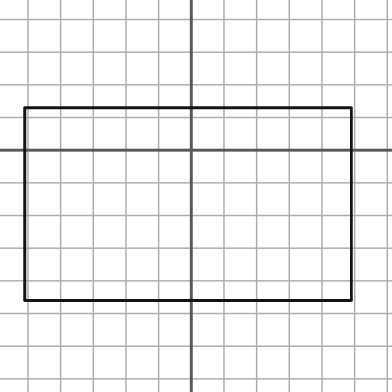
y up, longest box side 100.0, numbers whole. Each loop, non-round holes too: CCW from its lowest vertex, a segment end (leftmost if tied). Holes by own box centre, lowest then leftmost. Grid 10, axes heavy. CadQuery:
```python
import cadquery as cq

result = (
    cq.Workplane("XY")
    .moveTo(-51.0, -46.0)
    .lineTo(49.0, -46.0)
    .lineTo(49.0, 13.0)
    .lineTo(-51.0, 13.0)
    .close()
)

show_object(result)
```